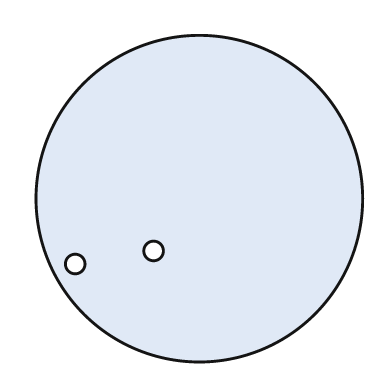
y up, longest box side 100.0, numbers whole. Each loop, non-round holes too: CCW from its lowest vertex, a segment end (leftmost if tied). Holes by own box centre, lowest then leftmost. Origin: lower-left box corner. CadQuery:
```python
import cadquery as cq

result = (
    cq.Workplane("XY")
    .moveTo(50.0, 50.0)
    .circle(50.0)
    .moveTo(12.0, 30.0)
    .circle(3.0)
    .moveTo(36.0, 34.0)
    .circle(3.0)
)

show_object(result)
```